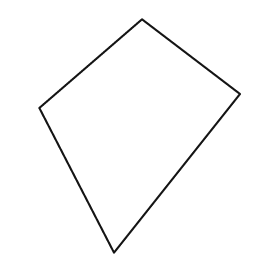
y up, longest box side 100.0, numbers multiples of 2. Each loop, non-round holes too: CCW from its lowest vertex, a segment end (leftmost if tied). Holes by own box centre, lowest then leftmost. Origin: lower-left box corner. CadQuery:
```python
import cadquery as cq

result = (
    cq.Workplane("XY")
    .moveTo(32.0, 0.0)
    .lineTo(86.0, 68.0)
    .lineTo(44.0, 100.0)
    .lineTo(0.0, 62.0)
    .close()
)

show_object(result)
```